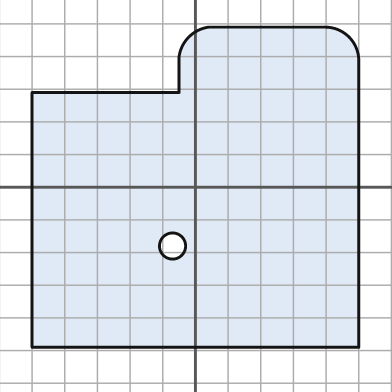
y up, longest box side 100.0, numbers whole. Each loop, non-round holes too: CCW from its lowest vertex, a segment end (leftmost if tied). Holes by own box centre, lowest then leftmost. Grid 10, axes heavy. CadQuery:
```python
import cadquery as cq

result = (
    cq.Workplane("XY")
    .moveTo(-50.0, -49.0)
    .lineTo(50.0, -49.0)
    .lineTo(50.0, 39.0)
    .threePointArc((47.0, 46.0), (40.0, 49.0))
    .lineTo(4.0, 49.0)
    .threePointArc((-2.0, 46.0), (-5.0, 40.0))
    .lineTo(-5.0, 29.0)
    .lineTo(-50.0, 29.0)
    .close()
    .moveTo(-7.0, -18.0)
    .circle(4.0)
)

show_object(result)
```